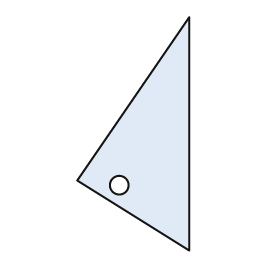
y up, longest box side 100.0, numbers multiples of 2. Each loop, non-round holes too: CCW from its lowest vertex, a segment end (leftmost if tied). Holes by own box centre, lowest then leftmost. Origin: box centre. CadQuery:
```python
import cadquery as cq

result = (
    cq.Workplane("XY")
    .moveTo(24.0, -50.0)
    .lineTo(24.0, 50.0)
    .lineTo(-24.0, -20.0)
    .close()
    .moveTo(-6.0, -22.0)
    .circle(4.0)
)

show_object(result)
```